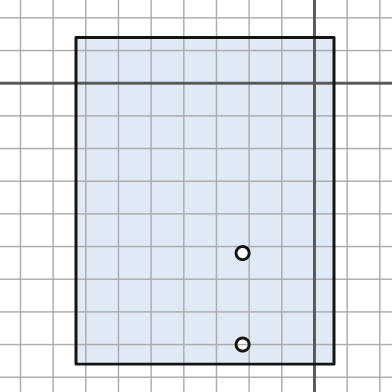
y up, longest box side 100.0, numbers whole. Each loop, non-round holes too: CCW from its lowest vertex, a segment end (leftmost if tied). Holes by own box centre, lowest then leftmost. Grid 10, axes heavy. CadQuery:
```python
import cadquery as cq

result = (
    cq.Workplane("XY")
    .moveTo(-73.0, -86.0)
    .lineTo(6.0, -86.0)
    .lineTo(6.0, 14.0)
    .lineTo(-73.0, 14.0)
    .close()
    .moveTo(-22.0, -80.0)
    .circle(2.0)
    .moveTo(-22.0, -52.0)
    .circle(2.0)
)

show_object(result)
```